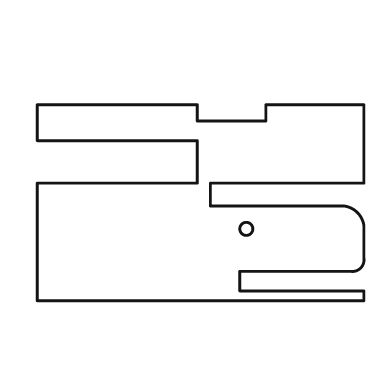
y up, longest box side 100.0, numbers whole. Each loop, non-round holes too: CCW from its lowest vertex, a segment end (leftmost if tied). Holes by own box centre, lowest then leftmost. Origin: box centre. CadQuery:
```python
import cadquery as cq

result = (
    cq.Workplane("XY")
    .moveTo(-50.0, -30.0)
    .lineTo(50.0, -30.0)
    .lineTo(50.0, -27.0)
    .lineTo(12.0, -27.0)
    .lineTo(12.0, -21.0)
    .lineTo(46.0, -21.0)
    .threePointArc((49.0, -20.0), (50.0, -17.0))
    .lineTo(50.0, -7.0)
    .threePointArc((48.0, -3.0), (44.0, -1.0))
    .lineTo(3.0, -1.0)
    .lineTo(3.0, 6.0)
    .lineTo(50.0, 6.0)
    .lineTo(50.0, 30.0)
    .lineTo(20.0, 30.0)
    .lineTo(20.0, 25.0)
    .lineTo(-1.0, 25.0)
    .lineTo(-1.0, 30.0)
    .lineTo(-50.0, 30.0)
    .lineTo(-50.0, 19.0)
    .lineTo(-1.0, 19.0)
    .lineTo(-1.0, 6.0)
    .lineTo(-50.0, 6.0)
    .close()
    .moveTo(14.0, -8.0)
    .circle(2.0)
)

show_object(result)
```